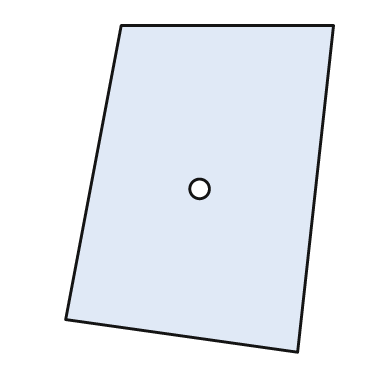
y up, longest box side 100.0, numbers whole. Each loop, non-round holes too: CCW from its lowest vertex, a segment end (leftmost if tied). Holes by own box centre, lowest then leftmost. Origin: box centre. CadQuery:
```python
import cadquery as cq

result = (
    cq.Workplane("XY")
    .moveTo(30.0, -50.0)
    .lineTo(41.0, 50.0)
    .lineTo(-24.0, 50.0)
    .lineTo(-41.0, -40.0)
    .close()
    .moveTo(0.0, 0.0)
    .circle(3.0)
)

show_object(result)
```